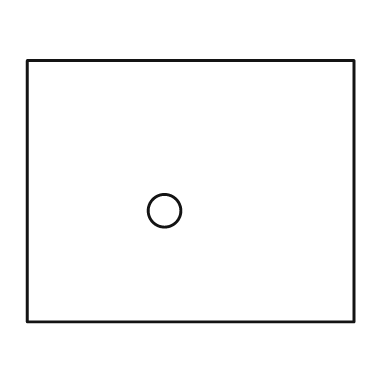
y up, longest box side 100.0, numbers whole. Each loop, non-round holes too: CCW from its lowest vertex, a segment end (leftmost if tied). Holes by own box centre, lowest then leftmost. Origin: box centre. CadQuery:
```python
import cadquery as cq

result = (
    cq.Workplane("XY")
    .moveTo(-50.0, -40.0)
    .lineTo(50.0, -40.0)
    .lineTo(50.0, 40.0)
    .lineTo(-50.0, 40.0)
    .close()
    .moveTo(-8.0, -6.0)
    .circle(5.0)
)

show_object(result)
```